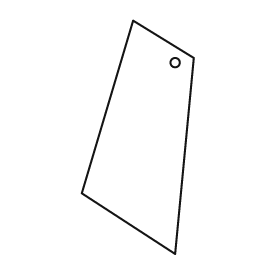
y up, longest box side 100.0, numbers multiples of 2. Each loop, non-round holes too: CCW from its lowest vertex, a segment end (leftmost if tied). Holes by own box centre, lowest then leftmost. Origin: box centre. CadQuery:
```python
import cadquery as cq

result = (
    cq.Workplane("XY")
    .moveTo(16.0, -50.0)
    .lineTo(24.0, 34.0)
    .lineTo(-2.0, 50.0)
    .lineTo(-24.0, -24.0)
    .close()
    .moveTo(16.0, 32.0)
    .circle(2.0)
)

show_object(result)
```